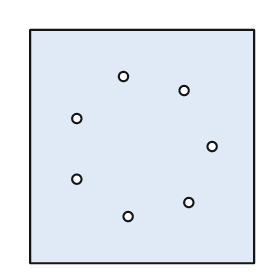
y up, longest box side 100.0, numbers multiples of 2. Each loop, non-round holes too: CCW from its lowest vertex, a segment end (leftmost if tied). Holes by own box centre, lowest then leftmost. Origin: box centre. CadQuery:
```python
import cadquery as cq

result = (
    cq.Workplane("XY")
    .moveTo(-48.0, -50.0)
    .lineTo(48.0, -50.0)
    .lineTo(48.0, 50.0)
    .lineTo(-48.0, 50.0)
    .close()
    .moveTo(-6.0, -30.0)
    .circle(2.0)
    .moveTo(20.0, -24.0)
    .circle(2.0)
    .moveTo(-28.0, -14.0)
    .circle(2.0)
    .moveTo(30.0, 0.0)
    .circle(2.0)
    .moveTo(-28.0, 12.0)
    .circle(2.0)
    .moveTo(18.0, 24.0)
    .circle(2.0)
    .moveTo(-8.0, 30.0)
    .circle(2.0)
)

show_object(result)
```